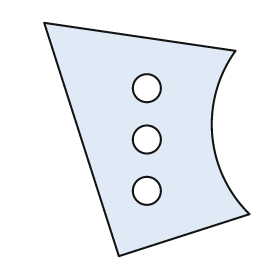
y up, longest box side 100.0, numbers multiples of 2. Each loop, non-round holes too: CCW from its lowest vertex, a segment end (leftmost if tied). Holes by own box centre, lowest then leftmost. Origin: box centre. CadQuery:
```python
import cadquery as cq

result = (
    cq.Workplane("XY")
    .moveTo(-12.0, -50.0)
    .lineTo(44.0, -32.0)
    .threePointArc((28.0, 2.0), (38.0, 38.0))
    .lineTo(-44.0, 50.0)
    .close()
    .moveTo(0.0, -22.0)
    .circle(6.0)
    .moveTo(0.0, 0.0)
    .circle(6.0)
    .moveTo(0.0, 22.0)
    .circle(6.0)
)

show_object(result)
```